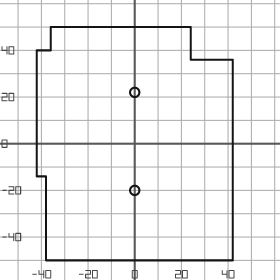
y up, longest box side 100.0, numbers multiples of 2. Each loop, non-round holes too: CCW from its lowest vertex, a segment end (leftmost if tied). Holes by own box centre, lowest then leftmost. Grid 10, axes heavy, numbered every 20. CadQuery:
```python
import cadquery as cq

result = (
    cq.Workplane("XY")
    .moveTo(-38.0, -50.0)
    .lineTo(42.0, -50.0)
    .lineTo(42.0, 36.0)
    .lineTo(24.0, 36.0)
    .lineTo(24.0, 50.0)
    .lineTo(-36.0, 50.0)
    .lineTo(-36.0, 40.0)
    .lineTo(-42.0, 40.0)
    .lineTo(-42.0, -14.0)
    .lineTo(-38.0, -14.0)
    .close()
    .moveTo(0.0, -20.0)
    .circle(2.0)
    .moveTo(0.0, 22.0)
    .circle(2.0)
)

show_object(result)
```